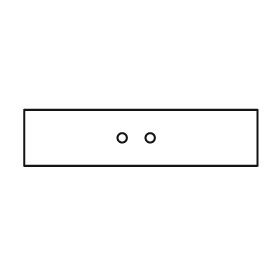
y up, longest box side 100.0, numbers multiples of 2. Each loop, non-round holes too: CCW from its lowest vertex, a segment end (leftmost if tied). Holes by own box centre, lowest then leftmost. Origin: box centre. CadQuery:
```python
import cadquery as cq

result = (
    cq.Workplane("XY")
    .moveTo(-50.0, -12.0)
    .lineTo(50.0, -12.0)
    .lineTo(50.0, 12.0)
    .lineTo(-50.0, 12.0)
    .close()
    .moveTo(-8.0, 0.0)
    .circle(2.0)
    .moveTo(4.0, 0.0)
    .circle(2.0)
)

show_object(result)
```